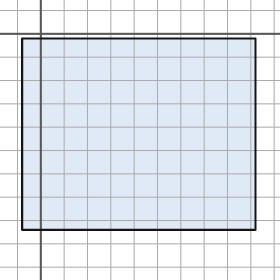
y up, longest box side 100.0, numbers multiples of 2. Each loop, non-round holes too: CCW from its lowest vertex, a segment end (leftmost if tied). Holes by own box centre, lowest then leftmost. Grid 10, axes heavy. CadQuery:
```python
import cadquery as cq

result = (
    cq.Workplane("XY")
    .moveTo(-8.0, -84.0)
    .lineTo(92.0, -84.0)
    .lineTo(92.0, -2.0)
    .lineTo(-8.0, -2.0)
    .close()
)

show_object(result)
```